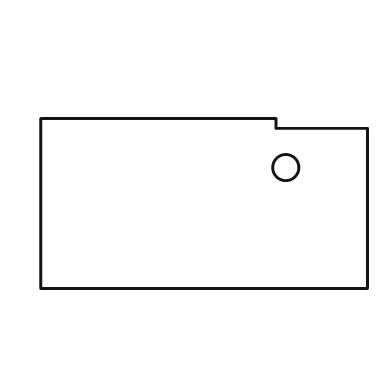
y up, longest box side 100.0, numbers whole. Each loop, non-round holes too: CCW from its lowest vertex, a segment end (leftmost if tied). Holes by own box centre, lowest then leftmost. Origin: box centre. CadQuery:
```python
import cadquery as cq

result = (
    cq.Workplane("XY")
    .moveTo(-50.0, -26.0)
    .lineTo(50.0, -26.0)
    .lineTo(50.0, 23.0)
    .lineTo(22.0, 23.0)
    .lineTo(22.0, 26.0)
    .lineTo(-50.0, 26.0)
    .close()
    .moveTo(25.0, 11.0)
    .circle(4.0)
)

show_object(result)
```